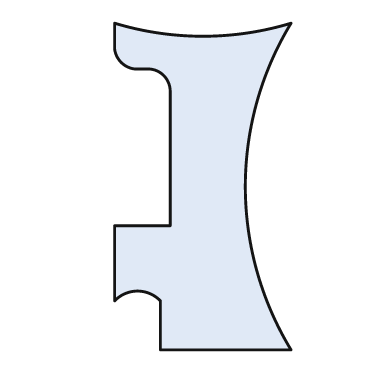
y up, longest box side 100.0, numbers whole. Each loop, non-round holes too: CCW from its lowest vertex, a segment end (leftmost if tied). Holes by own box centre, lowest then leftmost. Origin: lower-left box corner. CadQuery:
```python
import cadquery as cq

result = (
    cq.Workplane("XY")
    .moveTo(14.0, 0.0)
    .lineTo(54.0, 0.0)
    .threePointArc((40.0, 50.0), (54.0, 100.0))
    .threePointArc((27.0, 96.0), (0.0, 100.0))
    .lineTo(0.0, 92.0)
    .threePointArc((2.0, 88.0), (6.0, 86.0))
    .lineTo(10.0, 86.0)
    .threePointArc((15.0, 84.0), (17.0, 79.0))
    .lineTo(17.0, 38.0)
    .lineTo(0.0, 38.0)
    .lineTo(0.0, 15.0)
    .threePointArc((7.0, 18.0), (14.0, 15.0))
    .close()
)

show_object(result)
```